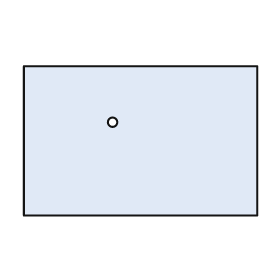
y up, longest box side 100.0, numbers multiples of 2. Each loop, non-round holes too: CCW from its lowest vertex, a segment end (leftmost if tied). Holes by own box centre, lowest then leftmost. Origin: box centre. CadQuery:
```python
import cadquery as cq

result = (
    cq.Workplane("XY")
    .moveTo(-50.0, -32.0)
    .lineTo(50.0, -32.0)
    .lineTo(50.0, 32.0)
    .lineTo(-50.0, 32.0)
    .close()
    .moveTo(-12.0, 8.0)
    .circle(2.0)
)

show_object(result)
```